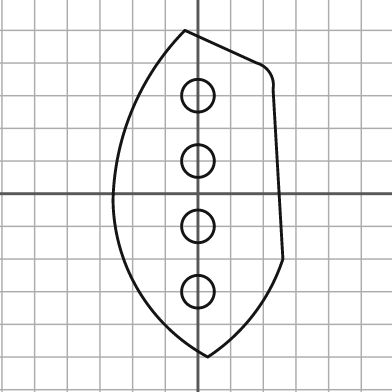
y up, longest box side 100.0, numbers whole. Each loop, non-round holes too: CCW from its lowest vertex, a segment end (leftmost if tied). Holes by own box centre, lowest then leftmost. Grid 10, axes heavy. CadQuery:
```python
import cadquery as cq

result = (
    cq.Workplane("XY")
    .moveTo(3.0, -50.0)
    .threePointArc((17.0, -37.0), (26.0, -20.0))
    .lineTo(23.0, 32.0)
    .threePointArc((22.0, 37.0), (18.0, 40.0))
    .lineTo(-4.0, 50.0)
    .threePointArc((-20.0, 26.0), (-26.0, -2.0))
    .threePointArc((-18.0, -30.0), (3.0, -50.0))
    .close()
    .moveTo(0.0, -30.0)
    .circle(5.0)
    .moveTo(0.0, -10.0)
    .circle(5.0)
    .moveTo(0.0, 10.0)
    .circle(5.0)
    .moveTo(0.0, 30.0)
    .circle(5.0)
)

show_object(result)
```